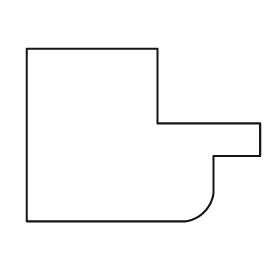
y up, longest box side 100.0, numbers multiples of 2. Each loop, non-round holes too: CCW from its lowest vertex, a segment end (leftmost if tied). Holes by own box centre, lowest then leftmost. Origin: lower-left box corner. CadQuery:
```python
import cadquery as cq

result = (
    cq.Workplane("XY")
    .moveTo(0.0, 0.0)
    .lineTo(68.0, 0.0)
    .threePointArc((76.0, 4.0), (80.0, 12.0))
    .lineTo(80.0, 28.0)
    .lineTo(100.0, 28.0)
    .lineTo(100.0, 42.0)
    .lineTo(56.0, 42.0)
    .lineTo(56.0, 74.0)
    .lineTo(0.0, 74.0)
    .close()
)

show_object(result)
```